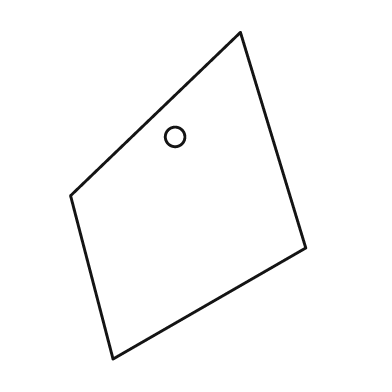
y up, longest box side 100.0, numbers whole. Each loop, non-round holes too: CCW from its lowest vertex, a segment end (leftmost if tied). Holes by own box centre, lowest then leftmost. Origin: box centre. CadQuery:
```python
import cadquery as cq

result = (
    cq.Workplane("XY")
    .moveTo(-23.0, -50.0)
    .lineTo(36.0, -16.0)
    .lineTo(16.0, 50.0)
    .lineTo(-36.0, 0.0)
    .close()
    .moveTo(-4.0, 18.0)
    .circle(3.0)
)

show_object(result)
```